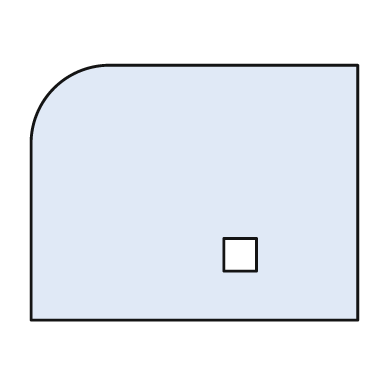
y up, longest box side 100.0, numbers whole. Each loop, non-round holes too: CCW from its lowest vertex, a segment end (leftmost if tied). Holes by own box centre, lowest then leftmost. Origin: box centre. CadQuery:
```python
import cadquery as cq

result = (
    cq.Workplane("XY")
    .moveTo(-50.0, -39.0)
    .lineTo(50.0, -39.0)
    .lineTo(50.0, 39.0)
    .lineTo(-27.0, 39.0)
    .threePointArc((-43.0, 32.0), (-50.0, 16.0))
    .close()
    .moveTo(9.0, -24.0)
    .lineTo(19.0, -24.0)
    .lineTo(19.0, -14.0)
    .lineTo(9.0, -14.0)
    .close()
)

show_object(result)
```